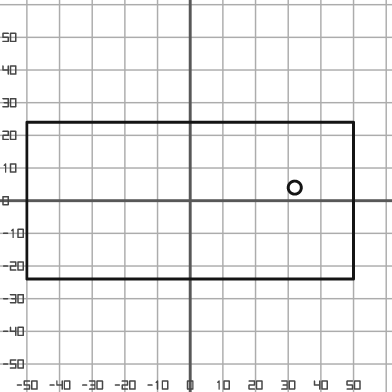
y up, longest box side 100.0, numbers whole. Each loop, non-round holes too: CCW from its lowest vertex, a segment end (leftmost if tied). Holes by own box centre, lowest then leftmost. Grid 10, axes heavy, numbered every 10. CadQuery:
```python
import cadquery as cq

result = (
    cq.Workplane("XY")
    .moveTo(-50.0, -24.0)
    .lineTo(50.0, -24.0)
    .lineTo(50.0, 24.0)
    .lineTo(-50.0, 24.0)
    .close()
    .moveTo(32.0, 4.0)
    .circle(2.0)
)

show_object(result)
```